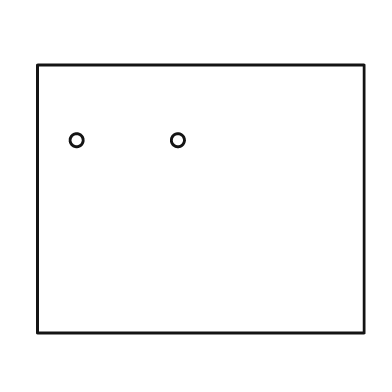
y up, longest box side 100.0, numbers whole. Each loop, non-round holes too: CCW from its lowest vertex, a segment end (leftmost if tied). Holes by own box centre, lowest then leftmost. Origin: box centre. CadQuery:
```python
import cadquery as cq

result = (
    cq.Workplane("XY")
    .moveTo(-50.0, -41.0)
    .lineTo(50.0, -41.0)
    .lineTo(50.0, 41.0)
    .lineTo(-50.0, 41.0)
    .close()
    .moveTo(-38.0, 18.0)
    .circle(2.0)
    .moveTo(-7.0, 18.0)
    .circle(2.0)
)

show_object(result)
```